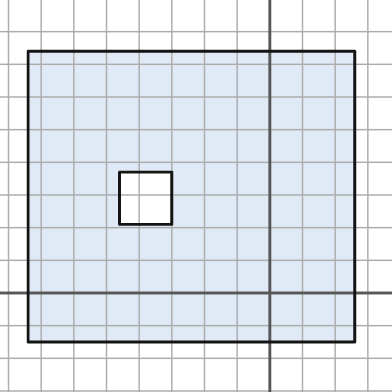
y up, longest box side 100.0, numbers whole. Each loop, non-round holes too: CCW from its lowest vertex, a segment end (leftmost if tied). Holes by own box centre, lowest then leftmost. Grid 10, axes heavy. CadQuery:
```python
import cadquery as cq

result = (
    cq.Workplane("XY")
    .moveTo(-74.0, -15.0)
    .lineTo(26.0, -15.0)
    .lineTo(26.0, 74.0)
    .lineTo(-74.0, 74.0)
    .close()
    .moveTo(-46.0, 21.0)
    .lineTo(-30.0, 21.0)
    .lineTo(-30.0, 37.0)
    .lineTo(-46.0, 37.0)
    .close()
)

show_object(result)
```